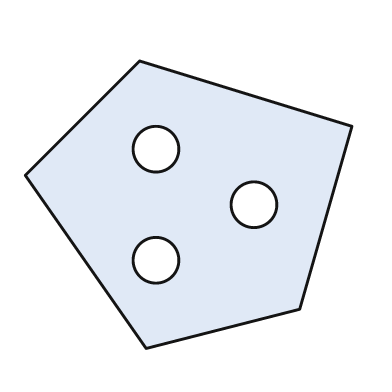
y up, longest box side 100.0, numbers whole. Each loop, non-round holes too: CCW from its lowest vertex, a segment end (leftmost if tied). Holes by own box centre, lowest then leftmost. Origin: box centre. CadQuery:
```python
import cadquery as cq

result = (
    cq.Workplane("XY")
    .moveTo(-13.0, -44.0)
    .lineTo(34.0, -32.0)
    .lineTo(50.0, 24.0)
    .lineTo(-15.0, 44.0)
    .lineTo(-50.0, 9.0)
    .close()
    .moveTo(-10.0, -17.0)
    .circle(7.0)
    .moveTo(20.0, 0.0)
    .circle(7.0)
    .moveTo(-10.0, 17.0)
    .circle(7.0)
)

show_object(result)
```